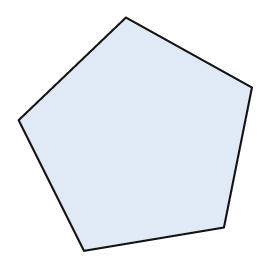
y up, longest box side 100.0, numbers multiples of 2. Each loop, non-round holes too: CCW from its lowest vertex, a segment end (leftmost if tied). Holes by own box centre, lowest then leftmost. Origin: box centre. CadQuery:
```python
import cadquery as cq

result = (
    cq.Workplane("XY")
    .moveTo(-22.0, -50.0)
    .lineTo(38.0, -40.0)
    .lineTo(50.0, 20.0)
    .lineTo(-4.0, 50.0)
    .lineTo(-50.0, 6.0)
    .close()
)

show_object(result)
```